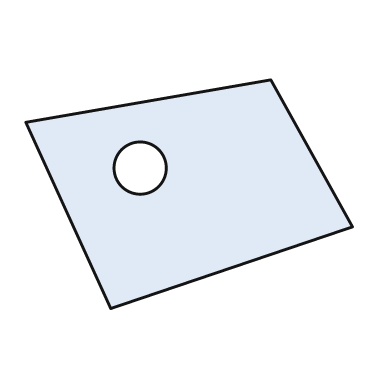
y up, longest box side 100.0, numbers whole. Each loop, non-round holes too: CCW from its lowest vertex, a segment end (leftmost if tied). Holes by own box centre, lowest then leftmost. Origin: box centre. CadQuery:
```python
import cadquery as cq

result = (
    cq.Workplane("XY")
    .moveTo(-24.0, -35.0)
    .lineTo(50.0, -10.0)
    .lineTo(25.0, 35.0)
    .lineTo(-50.0, 22.0)
    .close()
    .moveTo(-15.0, 8.0)
    .circle(8.0)
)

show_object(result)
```